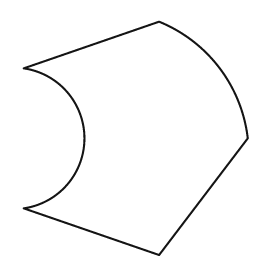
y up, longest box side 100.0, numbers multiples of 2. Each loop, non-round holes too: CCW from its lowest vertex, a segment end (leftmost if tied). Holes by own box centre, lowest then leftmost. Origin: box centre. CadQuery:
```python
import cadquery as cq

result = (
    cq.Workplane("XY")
    .moveTo(10.0, -50.0)
    .lineTo(48.0, 0.0)
    .threePointArc((36.0, 30.0), (10.0, 50.0))
    .lineTo(-48.0, 30.0)
    .threePointArc((-22.0, 0.0), (-48.0, -30.0))
    .close()
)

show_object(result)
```